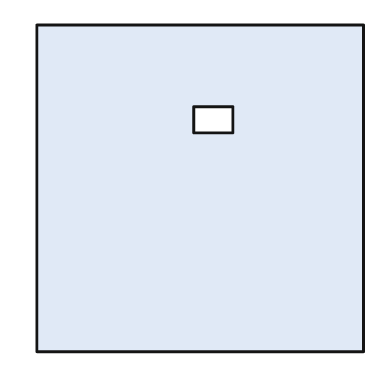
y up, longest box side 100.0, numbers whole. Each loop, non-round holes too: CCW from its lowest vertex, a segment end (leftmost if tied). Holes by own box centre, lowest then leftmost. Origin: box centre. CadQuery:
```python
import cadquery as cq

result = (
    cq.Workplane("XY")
    .moveTo(-50.0, -50.0)
    .lineTo(50.0, -50.0)
    .lineTo(50.0, 50.0)
    .lineTo(-50.0, 50.0)
    .close()
    .moveTo(-2.0, 17.0)
    .lineTo(10.0, 17.0)
    .lineTo(10.0, 25.0)
    .lineTo(-2.0, 25.0)
    .close()
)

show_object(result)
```